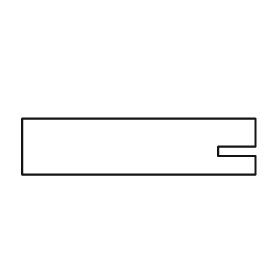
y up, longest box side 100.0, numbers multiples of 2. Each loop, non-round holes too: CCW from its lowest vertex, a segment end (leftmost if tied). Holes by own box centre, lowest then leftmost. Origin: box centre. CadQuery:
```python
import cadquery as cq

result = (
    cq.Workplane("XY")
    .moveTo(-50.0, -12.0)
    .lineTo(50.0, -12.0)
    .lineTo(50.0, -4.0)
    .lineTo(34.0, -4.0)
    .lineTo(34.0, 0.0)
    .lineTo(50.0, 0.0)
    .lineTo(50.0, 12.0)
    .lineTo(-50.0, 12.0)
    .close()
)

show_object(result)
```